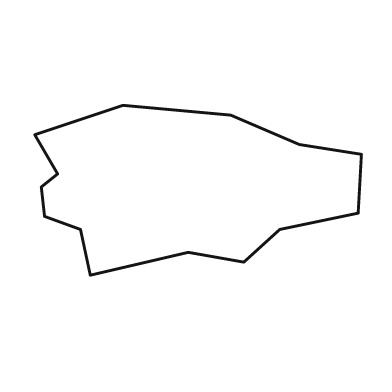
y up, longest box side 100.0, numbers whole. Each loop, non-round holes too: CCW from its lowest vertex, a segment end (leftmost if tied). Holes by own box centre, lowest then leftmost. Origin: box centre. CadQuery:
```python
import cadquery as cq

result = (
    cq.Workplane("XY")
    .moveTo(-33.0, -26.0)
    .lineTo(-3.0, -19.0)
    .lineTo(14.0, -22.0)
    .lineTo(25.0, -12.0)
    .lineTo(49.0, -7.0)
    .lineTo(50.0, 11.0)
    .lineTo(31.0, 14.0)
    .lineTo(10.0, 23.0)
    .lineTo(-23.0, 26.0)
    .lineTo(-50.0, 17.0)
    .lineTo(-43.0, 5.0)
    .lineTo(-48.0, 1.0)
    .lineTo(-47.0, -8.0)
    .lineTo(-36.0, -12.0)
    .close()
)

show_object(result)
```